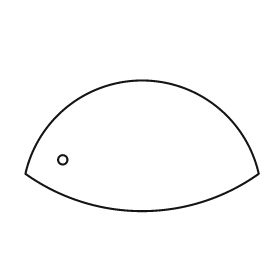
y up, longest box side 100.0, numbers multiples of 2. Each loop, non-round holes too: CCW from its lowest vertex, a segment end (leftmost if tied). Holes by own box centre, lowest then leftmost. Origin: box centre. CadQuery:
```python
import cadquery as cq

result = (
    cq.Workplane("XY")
    .moveTo(-50.0, -12.0)
    .threePointArc((0.0, -28.0), (50.0, -12.0))
    .threePointArc((0.0, 28.0), (-50.0, -12.0))
    .close()
    .moveTo(-34.0, -6.0)
    .circle(2.0)
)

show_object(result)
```